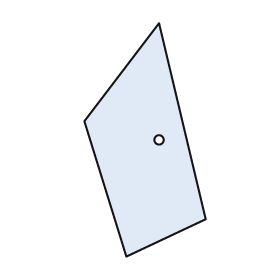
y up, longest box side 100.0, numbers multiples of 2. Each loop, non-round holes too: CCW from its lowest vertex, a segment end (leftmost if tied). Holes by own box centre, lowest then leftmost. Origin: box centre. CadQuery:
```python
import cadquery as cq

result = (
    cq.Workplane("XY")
    .moveTo(-8.0, -50.0)
    .lineTo(26.0, -34.0)
    .lineTo(6.0, 50.0)
    .lineTo(-26.0, 8.0)
    .close()
    .moveTo(6.0, 0.0)
    .circle(2.0)
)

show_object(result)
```